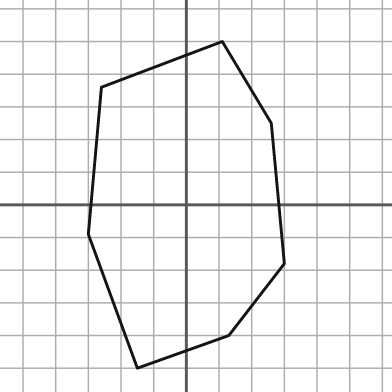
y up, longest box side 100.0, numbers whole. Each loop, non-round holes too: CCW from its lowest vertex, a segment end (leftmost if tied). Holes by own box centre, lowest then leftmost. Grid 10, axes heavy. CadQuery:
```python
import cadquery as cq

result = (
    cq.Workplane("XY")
    .moveTo(-15.0, -50.0)
    .lineTo(13.0, -40.0)
    .lineTo(30.0, -18.0)
    .lineTo(26.0, 25.0)
    .lineTo(11.0, 50.0)
    .lineTo(-26.0, 36.0)
    .lineTo(-30.0, -9.0)
    .close()
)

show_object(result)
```